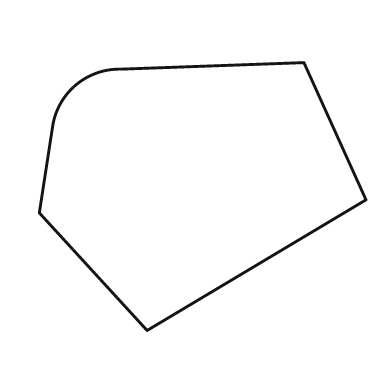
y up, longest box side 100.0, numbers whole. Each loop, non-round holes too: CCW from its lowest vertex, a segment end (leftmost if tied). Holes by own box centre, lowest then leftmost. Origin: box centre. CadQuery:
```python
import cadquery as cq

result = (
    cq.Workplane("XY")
    .moveTo(-17.0, -41.0)
    .lineTo(50.0, -1.0)
    .lineTo(31.0, 41.0)
    .lineTo(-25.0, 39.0)
    .threePointArc((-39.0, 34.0), (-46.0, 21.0))
    .lineTo(-50.0, -5.0)
    .close()
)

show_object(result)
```